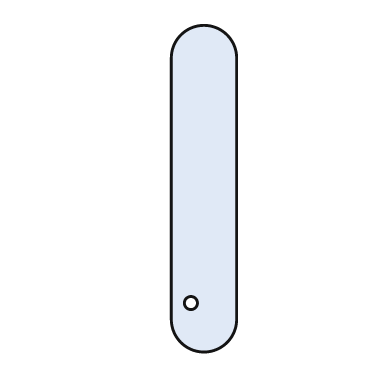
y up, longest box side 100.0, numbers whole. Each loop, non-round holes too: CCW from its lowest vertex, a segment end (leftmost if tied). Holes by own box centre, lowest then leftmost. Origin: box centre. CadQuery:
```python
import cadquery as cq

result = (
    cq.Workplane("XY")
    .moveTo(-10.0, -40.0)
    .threePointArc((0.0, -50.0), (10.0, -40.0))
    .lineTo(10.0, 40.0)
    .threePointArc((0.0, 50.0), (-10.0, 40.0))
    .close()
    .moveTo(-4.0, -35.0)
    .circle(2.0)
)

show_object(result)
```